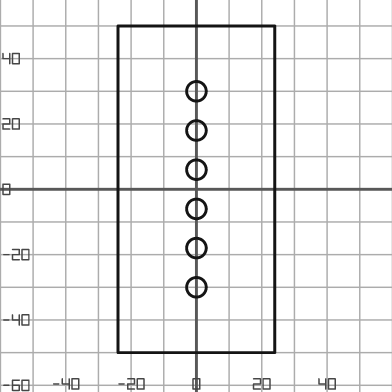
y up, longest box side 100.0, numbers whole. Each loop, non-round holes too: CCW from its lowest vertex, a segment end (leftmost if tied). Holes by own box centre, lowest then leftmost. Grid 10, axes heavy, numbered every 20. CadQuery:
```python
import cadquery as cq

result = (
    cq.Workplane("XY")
    .moveTo(-24.0, -50.0)
    .lineTo(24.0, -50.0)
    .lineTo(24.0, 50.0)
    .lineTo(-24.0, 50.0)
    .close()
    .moveTo(0.0, -30.0)
    .circle(3.0)
    .moveTo(0.0, -18.0)
    .circle(3.0)
    .moveTo(0.0, -6.0)
    .circle(3.0)
    .moveTo(0.0, 6.0)
    .circle(3.0)
    .moveTo(0.0, 18.0)
    .circle(3.0)
    .moveTo(0.0, 30.0)
    .circle(3.0)
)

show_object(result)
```